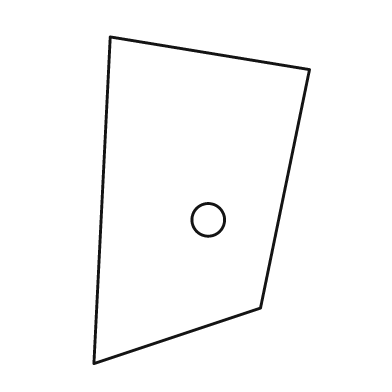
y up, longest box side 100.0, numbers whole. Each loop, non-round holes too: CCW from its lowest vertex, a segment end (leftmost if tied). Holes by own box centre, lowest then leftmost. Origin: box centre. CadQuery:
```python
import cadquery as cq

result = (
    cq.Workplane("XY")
    .moveTo(-33.0, -50.0)
    .lineTo(18.0, -33.0)
    .lineTo(33.0, 40.0)
    .lineTo(-28.0, 50.0)
    .close()
    .moveTo(2.0, -6.0)
    .circle(5.0)
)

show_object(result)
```